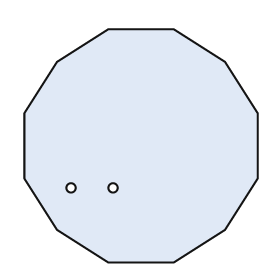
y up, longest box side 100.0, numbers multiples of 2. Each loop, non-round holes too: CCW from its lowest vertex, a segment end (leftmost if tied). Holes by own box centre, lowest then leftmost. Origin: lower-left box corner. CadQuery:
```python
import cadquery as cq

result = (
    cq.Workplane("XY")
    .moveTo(36.0, 0.0)
    .lineTo(64.0, 0.0)
    .lineTo(86.0, 14.0)
    .lineTo(100.0, 36.0)
    .lineTo(100.0, 64.0)
    .lineTo(86.0, 86.0)
    .lineTo(64.0, 100.0)
    .lineTo(36.0, 100.0)
    .lineTo(14.0, 86.0)
    .lineTo(0.0, 64.0)
    .lineTo(0.0, 36.0)
    .lineTo(14.0, 14.0)
    .close()
    .moveTo(20.0, 32.0)
    .circle(2.0)
    .moveTo(38.0, 32.0)
    .circle(2.0)
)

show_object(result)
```